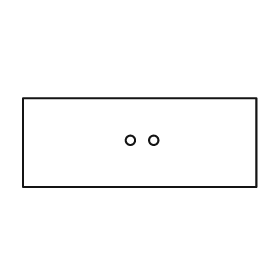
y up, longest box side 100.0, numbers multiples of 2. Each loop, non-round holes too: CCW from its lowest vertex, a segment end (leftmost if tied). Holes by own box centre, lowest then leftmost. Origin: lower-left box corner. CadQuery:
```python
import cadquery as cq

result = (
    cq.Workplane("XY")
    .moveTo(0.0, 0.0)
    .lineTo(100.0, 0.0)
    .lineTo(100.0, 38.0)
    .lineTo(0.0, 38.0)
    .close()
    .moveTo(46.0, 20.0)
    .circle(2.0)
    .moveTo(56.0, 20.0)
    .circle(2.0)
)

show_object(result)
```